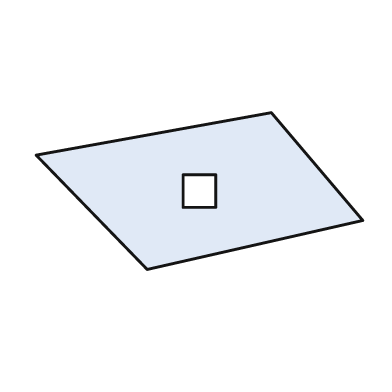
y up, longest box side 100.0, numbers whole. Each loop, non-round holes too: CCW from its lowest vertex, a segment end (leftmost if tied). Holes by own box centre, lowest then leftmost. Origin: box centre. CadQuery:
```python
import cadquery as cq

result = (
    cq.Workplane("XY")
    .moveTo(-16.0, -24.0)
    .lineTo(50.0, -9.0)
    .lineTo(22.0, 24.0)
    .lineTo(-50.0, 11.0)
    .close()
    .moveTo(-5.0, -5.0)
    .lineTo(5.0, -5.0)
    .lineTo(5.0, 5.0)
    .lineTo(-5.0, 5.0)
    .close()
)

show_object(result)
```